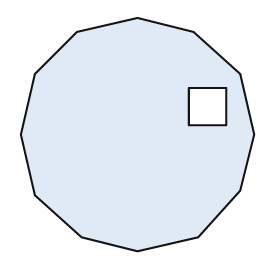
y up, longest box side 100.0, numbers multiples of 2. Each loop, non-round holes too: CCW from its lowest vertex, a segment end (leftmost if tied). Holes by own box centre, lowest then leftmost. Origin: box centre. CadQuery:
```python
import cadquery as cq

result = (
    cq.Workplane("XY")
    .moveTo(0.0, -50.0)
    .lineTo(26.0, -44.0)
    .lineTo(44.0, -24.0)
    .lineTo(50.0, 0.0)
    .lineTo(44.0, 26.0)
    .lineTo(24.0, 44.0)
    .lineTo(0.0, 50.0)
    .lineTo(-26.0, 44.0)
    .lineTo(-44.0, 26.0)
    .lineTo(-50.0, 0.0)
    .lineTo(-44.0, -26.0)
    .lineTo(-24.0, -44.0)
    .close()
    .moveTo(22.0, 4.0)
    .lineTo(38.0, 4.0)
    .lineTo(38.0, 20.0)
    .lineTo(22.0, 20.0)
    .close()
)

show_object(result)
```